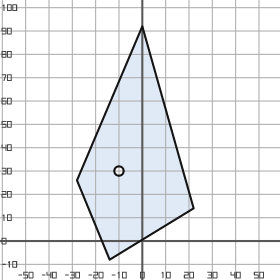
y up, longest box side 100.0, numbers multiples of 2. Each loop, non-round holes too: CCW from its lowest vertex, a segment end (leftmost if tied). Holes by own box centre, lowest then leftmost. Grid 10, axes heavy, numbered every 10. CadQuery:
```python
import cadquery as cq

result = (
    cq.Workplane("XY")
    .moveTo(-14.0, -8.0)
    .lineTo(22.0, 14.0)
    .lineTo(0.0, 92.0)
    .lineTo(-28.0, 26.0)
    .close()
    .moveTo(-10.0, 30.0)
    .circle(2.0)
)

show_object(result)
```